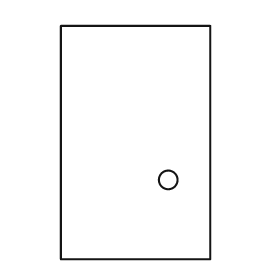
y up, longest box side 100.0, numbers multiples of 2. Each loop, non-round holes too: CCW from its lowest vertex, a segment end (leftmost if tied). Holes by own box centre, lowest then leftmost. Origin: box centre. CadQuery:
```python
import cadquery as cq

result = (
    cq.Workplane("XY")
    .moveTo(-32.0, -50.0)
    .lineTo(32.0, -50.0)
    .lineTo(32.0, 50.0)
    .lineTo(-32.0, 50.0)
    .close()
    .moveTo(14.0, -16.0)
    .circle(4.0)
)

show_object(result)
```